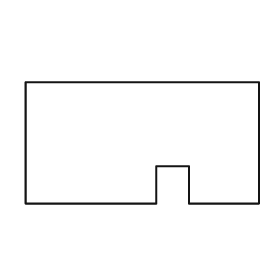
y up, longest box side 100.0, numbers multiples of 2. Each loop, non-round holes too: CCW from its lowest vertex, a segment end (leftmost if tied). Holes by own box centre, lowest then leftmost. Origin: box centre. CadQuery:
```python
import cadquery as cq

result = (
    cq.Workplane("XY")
    .moveTo(-50.0, -26.0)
    .lineTo(6.0, -26.0)
    .lineTo(6.0, -10.0)
    .lineTo(20.0, -10.0)
    .lineTo(20.0, -26.0)
    .lineTo(50.0, -26.0)
    .lineTo(50.0, 26.0)
    .lineTo(-50.0, 26.0)
    .close()
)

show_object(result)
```